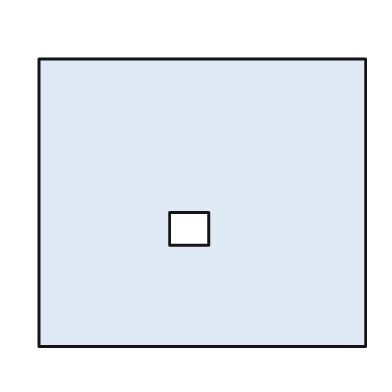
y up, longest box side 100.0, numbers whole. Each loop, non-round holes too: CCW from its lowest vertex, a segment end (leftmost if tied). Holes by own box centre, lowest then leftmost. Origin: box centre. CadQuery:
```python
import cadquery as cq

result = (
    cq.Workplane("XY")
    .moveTo(-50.0, -44.0)
    .lineTo(50.0, -44.0)
    .lineTo(50.0, 44.0)
    .lineTo(-50.0, 44.0)
    .close()
    .moveTo(-10.0, -13.0)
    .lineTo(2.0, -13.0)
    .lineTo(2.0, -3.0)
    .lineTo(-10.0, -3.0)
    .close()
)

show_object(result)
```